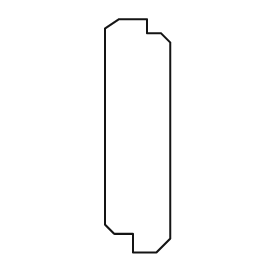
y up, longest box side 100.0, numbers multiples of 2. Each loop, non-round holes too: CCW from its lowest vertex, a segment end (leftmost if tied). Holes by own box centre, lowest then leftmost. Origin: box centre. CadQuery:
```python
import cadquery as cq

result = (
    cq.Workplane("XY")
    .moveTo(-2.0, -50.0)
    .lineTo(8.0, -50.0)
    .lineTo(14.0, -44.0)
    .lineTo(14.0, 40.0)
    .lineTo(10.0, 44.0)
    .lineTo(4.0, 44.0)
    .lineTo(4.0, 50.0)
    .lineTo(-8.0, 50.0)
    .lineTo(-14.0, 46.0)
    .lineTo(-14.0, -38.0)
    .lineTo(-10.0, -42.0)
    .lineTo(-2.0, -42.0)
    .close()
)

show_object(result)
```